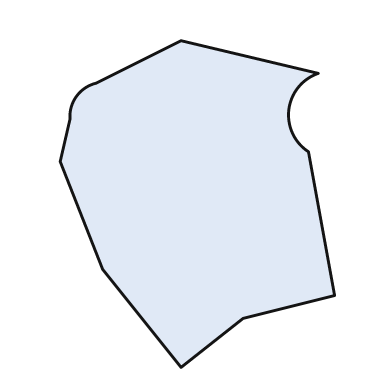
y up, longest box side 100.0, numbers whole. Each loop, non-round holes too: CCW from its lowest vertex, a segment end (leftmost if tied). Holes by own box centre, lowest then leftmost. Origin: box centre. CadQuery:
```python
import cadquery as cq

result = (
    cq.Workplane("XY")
    .moveTo(-5.0, -50.0)
    .lineTo(14.0, -35.0)
    .lineTo(42.0, -28.0)
    .lineTo(34.0, 16.0)
    .threePointArc((28.0, 29.0), (37.0, 40.0))
    .lineTo(-5.0, 50.0)
    .lineTo(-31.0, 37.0)
    .threePointArc((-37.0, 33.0), (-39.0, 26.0))
    .lineTo(-42.0, 13.0)
    .lineTo(-29.0, -20.0)
    .close()
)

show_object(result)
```